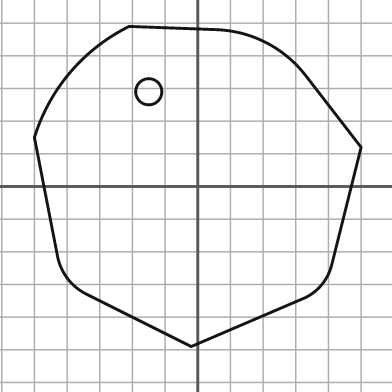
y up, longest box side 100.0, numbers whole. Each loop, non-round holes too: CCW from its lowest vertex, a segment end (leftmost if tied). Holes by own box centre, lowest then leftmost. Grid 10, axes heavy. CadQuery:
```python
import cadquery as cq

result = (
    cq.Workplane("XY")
    .moveTo(-2.0, -49.0)
    .lineTo(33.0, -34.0)
    .threePointArc((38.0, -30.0), (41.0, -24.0))
    .lineTo(50.0, 12.0)
    .lineTo(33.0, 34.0)
    .threePointArc((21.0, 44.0), (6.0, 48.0))
    .lineTo(-21.0, 49.0)
    .threePointArc((-39.0, 35.0), (-50.0, 15.0))
    .lineTo(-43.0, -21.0)
    .threePointArc((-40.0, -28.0), (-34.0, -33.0))
    .close()
    .moveTo(-15.0, 29.0)
    .circle(4.0)
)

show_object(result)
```